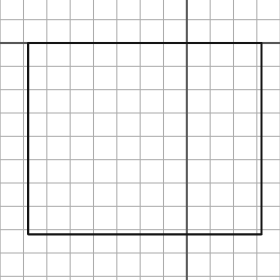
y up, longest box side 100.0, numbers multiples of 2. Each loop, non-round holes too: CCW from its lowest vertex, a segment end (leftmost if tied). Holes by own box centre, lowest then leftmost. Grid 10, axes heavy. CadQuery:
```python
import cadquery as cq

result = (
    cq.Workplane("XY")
    .moveTo(-68.0, -82.0)
    .lineTo(32.0, -82.0)
    .lineTo(32.0, 0.0)
    .lineTo(-68.0, 0.0)
    .close()
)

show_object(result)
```